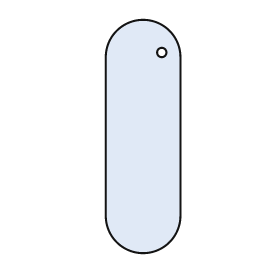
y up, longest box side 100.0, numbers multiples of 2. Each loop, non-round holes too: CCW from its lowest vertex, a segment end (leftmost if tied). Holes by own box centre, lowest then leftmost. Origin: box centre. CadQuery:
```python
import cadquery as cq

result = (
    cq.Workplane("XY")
    .moveTo(-16.0, -34.0)
    .threePointArc((0.0, -50.0), (16.0, -34.0))
    .lineTo(16.0, 34.0)
    .threePointArc((0.0, 50.0), (-16.0, 34.0))
    .close()
    .moveTo(8.0, 36.0)
    .circle(2.0)
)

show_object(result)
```